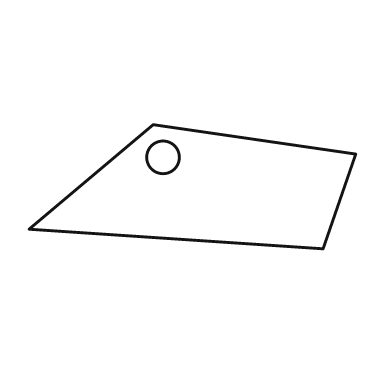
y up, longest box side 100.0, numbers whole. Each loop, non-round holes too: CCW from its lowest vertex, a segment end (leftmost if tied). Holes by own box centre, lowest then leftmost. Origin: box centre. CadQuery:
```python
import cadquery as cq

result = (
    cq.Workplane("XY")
    .moveTo(40.0, -19.0)
    .lineTo(50.0, 10.0)
    .lineTo(-12.0, 19.0)
    .lineTo(-50.0, -13.0)
    .close()
    .moveTo(-9.0, 9.0)
    .circle(5.0)
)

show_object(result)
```